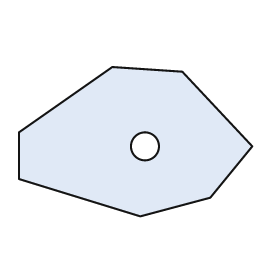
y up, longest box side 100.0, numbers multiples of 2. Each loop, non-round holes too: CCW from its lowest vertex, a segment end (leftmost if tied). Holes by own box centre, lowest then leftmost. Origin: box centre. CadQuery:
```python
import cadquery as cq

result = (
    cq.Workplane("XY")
    .moveTo(2.0, -32.0)
    .lineTo(32.0, -24.0)
    .lineTo(50.0, -2.0)
    .lineTo(20.0, 30.0)
    .lineTo(-10.0, 32.0)
    .lineTo(-50.0, 4.0)
    .lineTo(-50.0, -16.0)
    .close()
    .moveTo(4.0, -2.0)
    .circle(6.0)
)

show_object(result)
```